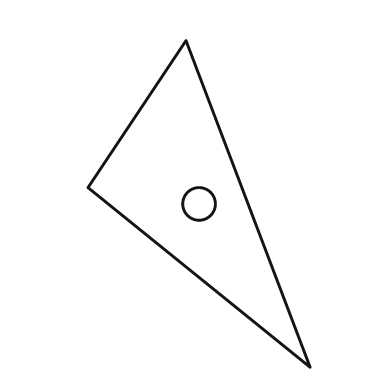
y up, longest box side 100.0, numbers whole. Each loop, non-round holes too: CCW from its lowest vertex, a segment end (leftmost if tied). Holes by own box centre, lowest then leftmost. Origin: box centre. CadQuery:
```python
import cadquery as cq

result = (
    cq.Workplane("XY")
    .moveTo(34.0, -50.0)
    .lineTo(-4.0, 50.0)
    .lineTo(-34.0, 5.0)
    .close()
    .moveTo(0.0, 0.0)
    .circle(5.0)
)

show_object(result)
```